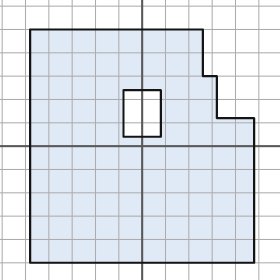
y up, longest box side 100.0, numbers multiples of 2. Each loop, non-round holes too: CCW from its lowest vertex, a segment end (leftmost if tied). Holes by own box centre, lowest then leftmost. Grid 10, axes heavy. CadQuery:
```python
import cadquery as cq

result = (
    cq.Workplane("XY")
    .moveTo(-48.0, -50.0)
    .lineTo(48.0, -50.0)
    .lineTo(48.0, 12.0)
    .lineTo(32.0, 12.0)
    .lineTo(32.0, 30.0)
    .lineTo(26.0, 30.0)
    .lineTo(26.0, 50.0)
    .lineTo(-48.0, 50.0)
    .close()
    .moveTo(-8.0, 4.0)
    .lineTo(8.0, 4.0)
    .lineTo(8.0, 24.0)
    .lineTo(-8.0, 24.0)
    .close()
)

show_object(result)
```